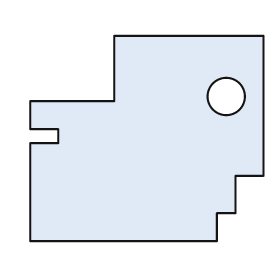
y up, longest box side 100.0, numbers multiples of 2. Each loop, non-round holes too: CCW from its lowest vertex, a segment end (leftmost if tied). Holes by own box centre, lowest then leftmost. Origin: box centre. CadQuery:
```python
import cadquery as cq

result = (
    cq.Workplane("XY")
    .moveTo(-50.0, -44.0)
    .lineTo(30.0, -44.0)
    .lineTo(30.0, -32.0)
    .lineTo(38.0, -32.0)
    .lineTo(38.0, -16.0)
    .lineTo(50.0, -16.0)
    .lineTo(50.0, 44.0)
    .lineTo(-14.0, 44.0)
    .lineTo(-14.0, 16.0)
    .lineTo(-50.0, 16.0)
    .lineTo(-50.0, 4.0)
    .lineTo(-38.0, 4.0)
    .lineTo(-38.0, -2.0)
    .lineTo(-50.0, -2.0)
    .close()
    .moveTo(34.0, 18.0)
    .circle(8.0)
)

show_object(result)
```